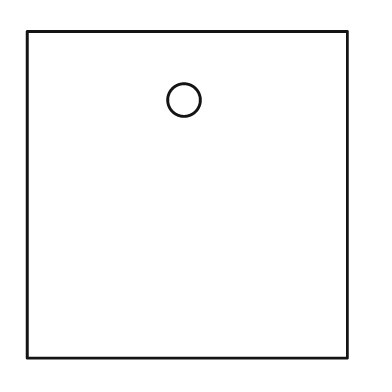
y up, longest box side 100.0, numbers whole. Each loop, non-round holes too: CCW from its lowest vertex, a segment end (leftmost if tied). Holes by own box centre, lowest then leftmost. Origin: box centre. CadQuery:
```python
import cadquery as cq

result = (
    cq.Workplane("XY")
    .moveTo(-49.0, -50.0)
    .lineTo(49.0, -50.0)
    .lineTo(49.0, 50.0)
    .lineTo(-49.0, 50.0)
    .close()
    .moveTo(-1.0, 29.0)
    .circle(5.0)
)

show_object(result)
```